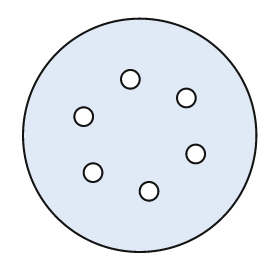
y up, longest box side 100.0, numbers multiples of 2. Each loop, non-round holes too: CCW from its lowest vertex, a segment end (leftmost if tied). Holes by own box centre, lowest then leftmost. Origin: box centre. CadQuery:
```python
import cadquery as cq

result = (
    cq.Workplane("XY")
    .moveTo(0.0, 0.0)
    .circle(50.0)
    .moveTo(4.0, -24.0)
    .circle(4.0)
    .moveTo(-20.0, -16.0)
    .circle(4.0)
    .moveTo(24.0, -8.0)
    .circle(4.0)
    .moveTo(-24.0, 8.0)
    .circle(4.0)
    .moveTo(20.0, 16.0)
    .circle(4.0)
    .moveTo(-4.0, 24.0)
    .circle(4.0)
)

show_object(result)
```